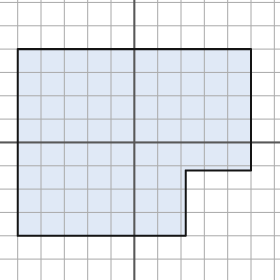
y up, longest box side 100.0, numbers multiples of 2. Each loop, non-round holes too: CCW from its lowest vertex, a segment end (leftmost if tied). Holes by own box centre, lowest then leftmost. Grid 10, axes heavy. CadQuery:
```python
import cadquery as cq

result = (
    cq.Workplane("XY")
    .moveTo(-50.0, -40.0)
    .lineTo(22.0, -40.0)
    .lineTo(22.0, -12.0)
    .lineTo(50.0, -12.0)
    .lineTo(50.0, 40.0)
    .lineTo(-50.0, 40.0)
    .close()
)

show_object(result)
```